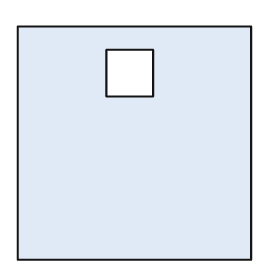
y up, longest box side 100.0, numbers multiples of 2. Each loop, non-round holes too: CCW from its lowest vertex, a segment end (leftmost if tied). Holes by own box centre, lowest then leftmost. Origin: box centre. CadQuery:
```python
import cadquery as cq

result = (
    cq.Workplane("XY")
    .moveTo(-50.0, -50.0)
    .lineTo(50.0, -50.0)
    .lineTo(50.0, 50.0)
    .lineTo(-50.0, 50.0)
    .close()
    .moveTo(-12.0, 20.0)
    .lineTo(8.0, 20.0)
    .lineTo(8.0, 40.0)
    .lineTo(-12.0, 40.0)
    .close()
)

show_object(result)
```